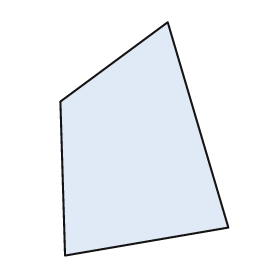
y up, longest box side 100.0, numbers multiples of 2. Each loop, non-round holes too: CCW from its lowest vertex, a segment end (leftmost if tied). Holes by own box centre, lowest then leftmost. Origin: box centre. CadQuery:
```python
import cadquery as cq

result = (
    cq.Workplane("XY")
    .moveTo(-34.0, -50.0)
    .lineTo(36.0, -38.0)
    .lineTo(10.0, 50.0)
    .lineTo(-36.0, 16.0)
    .close()
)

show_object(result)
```